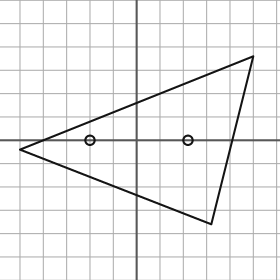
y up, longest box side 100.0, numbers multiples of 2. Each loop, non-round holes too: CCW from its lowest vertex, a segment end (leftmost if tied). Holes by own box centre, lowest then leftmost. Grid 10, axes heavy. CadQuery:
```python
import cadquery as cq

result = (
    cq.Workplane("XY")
    .moveTo(32.0, -36.0)
    .lineTo(50.0, 36.0)
    .lineTo(-50.0, -4.0)
    .close()
    .moveTo(-20.0, 0.0)
    .circle(2.0)
    .moveTo(22.0, 0.0)
    .circle(2.0)
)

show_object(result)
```